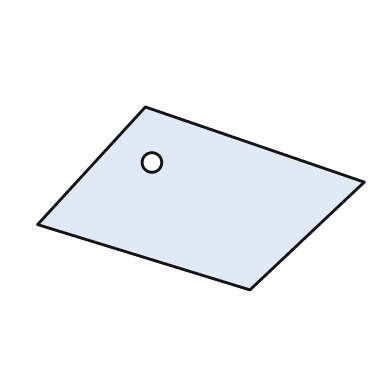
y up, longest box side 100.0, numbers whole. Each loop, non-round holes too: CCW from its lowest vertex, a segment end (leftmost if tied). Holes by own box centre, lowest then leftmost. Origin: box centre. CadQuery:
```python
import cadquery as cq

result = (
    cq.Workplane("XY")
    .moveTo(15.0, -28.0)
    .lineTo(50.0, 5.0)
    .lineTo(-17.0, 28.0)
    .lineTo(-50.0, -8.0)
    .close()
    .moveTo(-15.0, 11.0)
    .circle(3.0)
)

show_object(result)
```